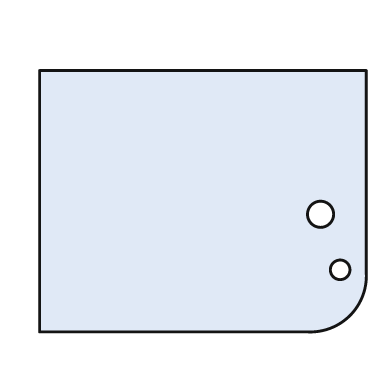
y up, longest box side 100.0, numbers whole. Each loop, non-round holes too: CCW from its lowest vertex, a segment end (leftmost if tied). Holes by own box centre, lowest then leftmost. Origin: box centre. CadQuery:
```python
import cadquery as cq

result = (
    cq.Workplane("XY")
    .moveTo(-50.0, -40.0)
    .lineTo(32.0, -40.0)
    .threePointArc((45.0, -35.0), (50.0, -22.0))
    .lineTo(50.0, 40.0)
    .lineTo(-50.0, 40.0)
    .close()
    .moveTo(42.0, -21.0)
    .circle(3.0)
    .moveTo(36.0, -4.0)
    .circle(4.0)
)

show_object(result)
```